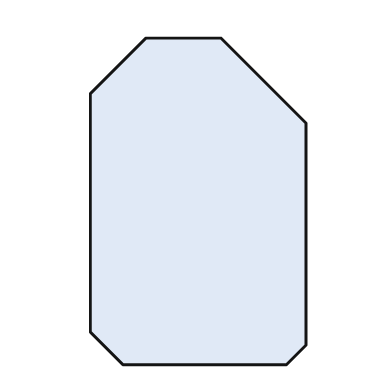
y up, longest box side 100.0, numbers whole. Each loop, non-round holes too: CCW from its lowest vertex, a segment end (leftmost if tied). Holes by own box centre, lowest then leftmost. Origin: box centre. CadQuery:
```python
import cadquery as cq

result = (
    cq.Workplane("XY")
    .moveTo(-23.0, -50.0)
    .lineTo(27.0, -50.0)
    .lineTo(33.0, -44.0)
    .lineTo(33.0, 24.0)
    .lineTo(7.0, 50.0)
    .lineTo(-16.0, 50.0)
    .lineTo(-33.0, 33.0)
    .lineTo(-33.0, -40.0)
    .close()
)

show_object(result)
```